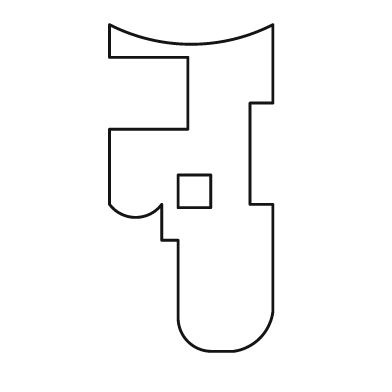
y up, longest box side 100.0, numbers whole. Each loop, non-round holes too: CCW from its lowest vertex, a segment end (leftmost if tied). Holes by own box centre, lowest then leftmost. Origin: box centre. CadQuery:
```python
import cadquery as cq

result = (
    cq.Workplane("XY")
    .moveTo(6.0, -50.0)
    .lineTo(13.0, -50.0)
    .threePointArc((21.0, -46.0), (25.0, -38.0))
    .lineTo(25.0, -5.0)
    .lineTo(18.0, -5.0)
    .lineTo(18.0, 26.0)
    .lineTo(25.0, 26.0)
    .lineTo(25.0, 50.0)
    .threePointArc((0.0, 44.0), (-25.0, 50.0))
    .lineTo(-25.0, 40.0)
    .lineTo(-1.0, 40.0)
    .lineTo(-1.0, 18.0)
    .lineTo(-25.0, 18.0)
    .lineTo(-25.0, -5.0)
    .threePointArc((-17.0, -9.0), (-9.0, -5.0))
    .lineTo(-9.0, -16.0)
    .lineTo(-4.0, -16.0)
    .lineTo(-4.0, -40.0)
    .threePointArc((-1.0, -47.0), (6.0, -50.0))
    .close()
    .moveTo(-4.0, -6.0)
    .lineTo(6.0, -6.0)
    .lineTo(6.0, 4.0)
    .lineTo(-4.0, 4.0)
    .close()
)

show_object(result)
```